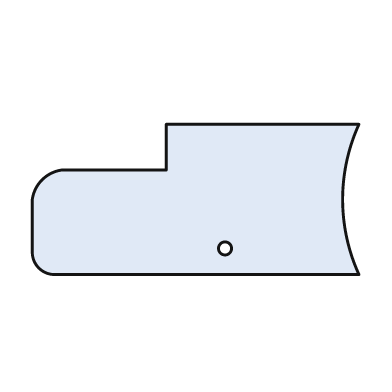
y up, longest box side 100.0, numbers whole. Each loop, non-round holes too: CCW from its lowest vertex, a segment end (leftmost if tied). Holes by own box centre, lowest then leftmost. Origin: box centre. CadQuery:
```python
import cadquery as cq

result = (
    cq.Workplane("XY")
    .moveTo(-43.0, -23.0)
    .lineTo(50.0, -23.0)
    .threePointArc((45.0, 0.0), (50.0, 23.0))
    .lineTo(-9.0, 23.0)
    .lineTo(-9.0, 9.0)
    .lineTo(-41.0, 9.0)
    .threePointArc((-47.0, 6.0), (-50.0, 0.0))
    .lineTo(-50.0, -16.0)
    .threePointArc((-48.0, -21.0), (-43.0, -23.0))
    .close()
    .moveTo(9.0, -15.0)
    .circle(2.0)
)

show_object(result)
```